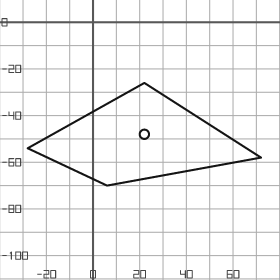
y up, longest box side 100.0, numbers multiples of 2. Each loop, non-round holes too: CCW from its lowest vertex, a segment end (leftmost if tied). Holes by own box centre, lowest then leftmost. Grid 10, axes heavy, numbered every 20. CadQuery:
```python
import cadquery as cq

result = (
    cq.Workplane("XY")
    .moveTo(6.0, -70.0)
    .lineTo(72.0, -58.0)
    .lineTo(22.0, -26.0)
    .lineTo(-28.0, -54.0)
    .close()
    .moveTo(22.0, -48.0)
    .circle(2.0)
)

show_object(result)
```